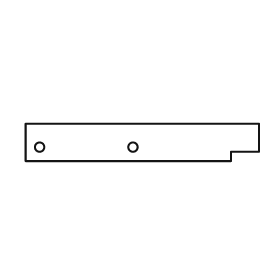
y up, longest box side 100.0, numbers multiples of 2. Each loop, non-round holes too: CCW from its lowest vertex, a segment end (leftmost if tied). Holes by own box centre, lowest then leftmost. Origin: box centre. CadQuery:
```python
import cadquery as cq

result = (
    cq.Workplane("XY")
    .moveTo(-50.0, -8.0)
    .lineTo(38.0, -8.0)
    .lineTo(38.0, -4.0)
    .lineTo(50.0, -4.0)
    .lineTo(50.0, 8.0)
    .lineTo(-50.0, 8.0)
    .close()
    .moveTo(-44.0, -2.0)
    .circle(2.0)
    .moveTo(-4.0, -2.0)
    .circle(2.0)
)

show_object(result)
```